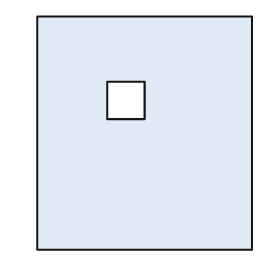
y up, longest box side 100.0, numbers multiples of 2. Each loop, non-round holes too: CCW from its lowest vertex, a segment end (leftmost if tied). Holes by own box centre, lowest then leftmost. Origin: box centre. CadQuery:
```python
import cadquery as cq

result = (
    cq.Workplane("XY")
    .moveTo(-46.0, -50.0)
    .lineTo(46.0, -50.0)
    .lineTo(46.0, 50.0)
    .lineTo(-46.0, 50.0)
    .close()
    .moveTo(-16.0, 6.0)
    .lineTo(0.0, 6.0)
    .lineTo(0.0, 22.0)
    .lineTo(-16.0, 22.0)
    .close()
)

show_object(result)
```